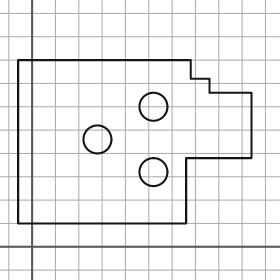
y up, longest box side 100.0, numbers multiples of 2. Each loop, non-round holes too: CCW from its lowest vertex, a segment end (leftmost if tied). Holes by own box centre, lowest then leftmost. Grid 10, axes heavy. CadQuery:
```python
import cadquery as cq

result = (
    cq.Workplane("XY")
    .moveTo(-6.0, 10.0)
    .lineTo(66.0, 10.0)
    .lineTo(66.0, 38.0)
    .lineTo(94.0, 38.0)
    .lineTo(94.0, 66.0)
    .lineTo(76.0, 66.0)
    .lineTo(76.0, 72.0)
    .lineTo(68.0, 72.0)
    .lineTo(68.0, 80.0)
    .lineTo(-6.0, 80.0)
    .close()
    .moveTo(52.0, 32.0)
    .circle(6.0)
    .moveTo(28.0, 46.0)
    .circle(6.0)
    .moveTo(52.0, 60.0)
    .circle(6.0)
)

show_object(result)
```